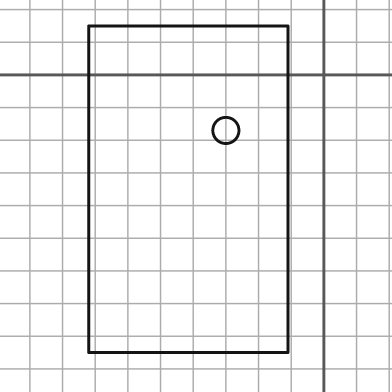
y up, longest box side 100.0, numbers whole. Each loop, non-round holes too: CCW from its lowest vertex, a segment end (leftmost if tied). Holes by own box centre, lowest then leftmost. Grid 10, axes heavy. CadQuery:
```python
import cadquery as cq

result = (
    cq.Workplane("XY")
    .moveTo(-72.0, -85.0)
    .lineTo(-11.0, -85.0)
    .lineTo(-11.0, 15.0)
    .lineTo(-72.0, 15.0)
    .close()
    .moveTo(-30.0, -17.0)
    .circle(4.0)
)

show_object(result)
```